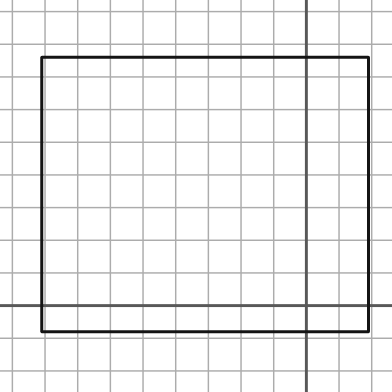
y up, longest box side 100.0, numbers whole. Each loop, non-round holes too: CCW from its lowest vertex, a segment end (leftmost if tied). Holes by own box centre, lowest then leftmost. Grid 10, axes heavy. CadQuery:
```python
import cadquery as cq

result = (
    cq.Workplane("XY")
    .moveTo(-81.0, -8.0)
    .lineTo(19.0, -8.0)
    .lineTo(19.0, 76.0)
    .lineTo(-81.0, 76.0)
    .close()
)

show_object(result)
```